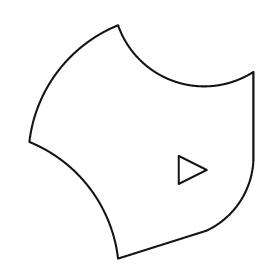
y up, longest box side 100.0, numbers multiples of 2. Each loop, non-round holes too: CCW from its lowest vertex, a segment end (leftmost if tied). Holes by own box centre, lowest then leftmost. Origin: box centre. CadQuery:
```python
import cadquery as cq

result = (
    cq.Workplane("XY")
    .moveTo(-10.0, -50.0)
    .lineTo(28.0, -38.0)
    .threePointArc((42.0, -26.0), (48.0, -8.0))
    .lineTo(48.0, 30.0)
    .threePointArc((14.0, 26.0), (-10.0, 50.0))
    .threePointArc((-36.0, 30.0), (-48.0, 0.0))
    .threePointArc((-22.0, -20.0), (-10.0, -50.0))
    .close()
    .moveTo(16.0, -18.0)
    .lineTo(28.0, -12.0)
    .lineTo(16.0, -6.0)
    .close()
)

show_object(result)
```